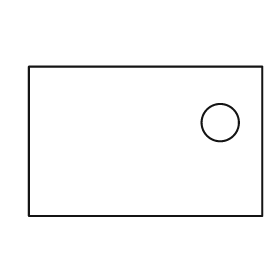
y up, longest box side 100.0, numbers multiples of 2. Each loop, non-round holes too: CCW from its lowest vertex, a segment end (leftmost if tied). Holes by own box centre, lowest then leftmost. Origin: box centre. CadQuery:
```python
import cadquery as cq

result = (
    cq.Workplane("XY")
    .moveTo(-50.0, -32.0)
    .lineTo(50.0, -32.0)
    .lineTo(50.0, 32.0)
    .lineTo(-50.0, 32.0)
    .close()
    .moveTo(32.0, 8.0)
    .circle(8.0)
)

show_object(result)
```